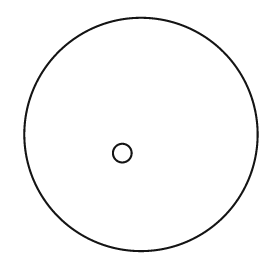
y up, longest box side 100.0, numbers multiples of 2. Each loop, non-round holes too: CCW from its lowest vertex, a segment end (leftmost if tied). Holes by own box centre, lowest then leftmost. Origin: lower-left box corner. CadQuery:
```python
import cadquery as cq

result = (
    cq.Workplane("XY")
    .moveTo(50.0, 50.0)
    .circle(50.0)
    .moveTo(42.0, 42.0)
    .circle(4.0)
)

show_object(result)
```